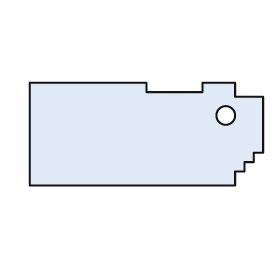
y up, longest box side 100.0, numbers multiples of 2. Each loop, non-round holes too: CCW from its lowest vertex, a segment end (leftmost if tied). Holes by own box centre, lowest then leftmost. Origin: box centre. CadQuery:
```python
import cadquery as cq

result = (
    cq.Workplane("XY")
    .moveTo(-50.0, -22.0)
    .lineTo(38.0, -22.0)
    .lineTo(38.0, -16.0)
    .lineTo(42.0, -16.0)
    .lineTo(42.0, -12.0)
    .lineTo(46.0, -12.0)
    .lineTo(46.0, -8.0)
    .lineTo(50.0, -8.0)
    .lineTo(50.0, 16.0)
    .lineTo(38.0, 16.0)
    .lineTo(38.0, 22.0)
    .lineTo(24.0, 22.0)
    .lineTo(24.0, 18.0)
    .lineTo(0.0, 18.0)
    .lineTo(0.0, 22.0)
    .lineTo(-50.0, 22.0)
    .close()
    .moveTo(34.0, 8.0)
    .circle(4.0)
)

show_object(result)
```